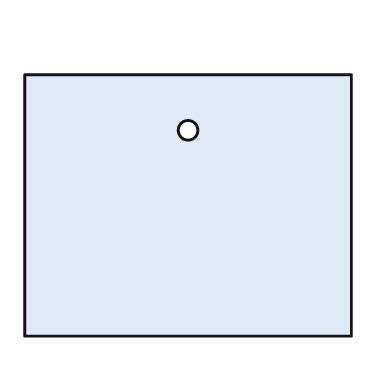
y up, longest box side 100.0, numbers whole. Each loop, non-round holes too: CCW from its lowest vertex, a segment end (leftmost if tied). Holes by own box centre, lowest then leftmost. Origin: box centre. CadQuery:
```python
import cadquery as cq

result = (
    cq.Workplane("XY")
    .moveTo(-50.0, -40.0)
    .lineTo(50.0, -40.0)
    .lineTo(50.0, 40.0)
    .lineTo(-50.0, 40.0)
    .close()
    .moveTo(0.0, 23.0)
    .circle(3.0)
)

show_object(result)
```